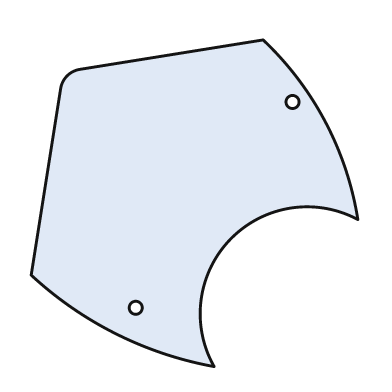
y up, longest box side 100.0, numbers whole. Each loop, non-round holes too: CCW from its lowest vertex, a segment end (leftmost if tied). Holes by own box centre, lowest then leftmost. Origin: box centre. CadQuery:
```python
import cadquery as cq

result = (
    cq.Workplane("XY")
    .moveTo(6.0, -50.0)
    .threePointArc((11.0, -11.0), (50.0, -5.0))
    .threePointArc((40.0, 25.0), (21.0, 50.0))
    .lineTo(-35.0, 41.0)
    .threePointArc((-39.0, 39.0), (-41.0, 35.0))
    .lineTo(-50.0, -22.0)
    .threePointArc((-24.0, -40.0), (6.0, -50.0))
    .close()
    .moveTo(-18.0, -32.0)
    .circle(2.0)
    .moveTo(30.0, 31.0)
    .circle(2.0)
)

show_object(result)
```